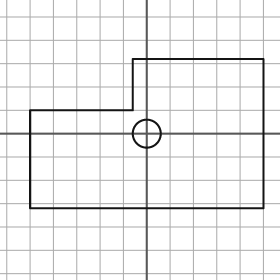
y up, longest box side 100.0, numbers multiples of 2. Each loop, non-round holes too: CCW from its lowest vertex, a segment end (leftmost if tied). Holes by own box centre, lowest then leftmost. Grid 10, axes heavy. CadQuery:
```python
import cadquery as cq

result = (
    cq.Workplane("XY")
    .moveTo(-50.0, -32.0)
    .lineTo(50.0, -32.0)
    .lineTo(50.0, 32.0)
    .lineTo(-6.0, 32.0)
    .lineTo(-6.0, 10.0)
    .lineTo(-50.0, 10.0)
    .close()
    .moveTo(0.0, 0.0)
    .circle(6.0)
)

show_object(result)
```